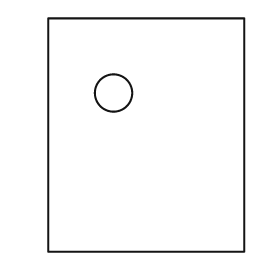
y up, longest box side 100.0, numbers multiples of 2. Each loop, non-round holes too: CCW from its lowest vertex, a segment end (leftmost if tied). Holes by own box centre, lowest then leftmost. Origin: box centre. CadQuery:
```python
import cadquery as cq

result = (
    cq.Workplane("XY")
    .moveTo(-42.0, -50.0)
    .lineTo(42.0, -50.0)
    .lineTo(42.0, 50.0)
    .lineTo(-42.0, 50.0)
    .close()
    .moveTo(-14.0, 18.0)
    .circle(8.0)
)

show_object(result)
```